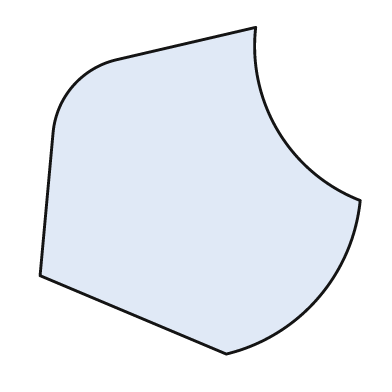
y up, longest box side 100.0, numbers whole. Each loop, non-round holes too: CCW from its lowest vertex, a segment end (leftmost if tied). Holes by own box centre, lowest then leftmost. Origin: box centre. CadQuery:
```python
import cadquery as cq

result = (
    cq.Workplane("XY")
    .moveTo(8.0, -50.0)
    .threePointArc((36.0, -33.0), (49.0, -3.0))
    .threePointArc((24.0, 18.0), (17.0, 50.0))
    .lineTo(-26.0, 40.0)
    .threePointArc((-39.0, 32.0), (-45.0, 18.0))
    .lineTo(-49.0, -26.0)
    .close()
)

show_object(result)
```